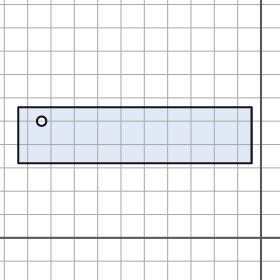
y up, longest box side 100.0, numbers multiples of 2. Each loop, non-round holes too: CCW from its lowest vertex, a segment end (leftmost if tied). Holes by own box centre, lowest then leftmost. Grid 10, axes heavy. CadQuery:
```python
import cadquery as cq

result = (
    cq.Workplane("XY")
    .moveTo(-104.0, 32.0)
    .lineTo(-4.0, 32.0)
    .lineTo(-4.0, 56.0)
    .lineTo(-104.0, 56.0)
    .close()
    .moveTo(-94.0, 50.0)
    .circle(2.0)
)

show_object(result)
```